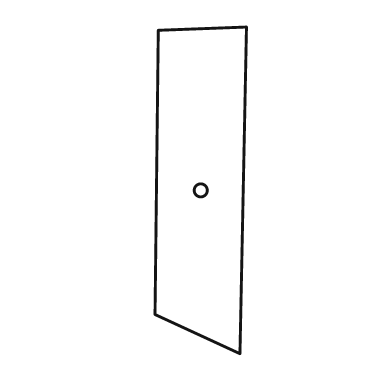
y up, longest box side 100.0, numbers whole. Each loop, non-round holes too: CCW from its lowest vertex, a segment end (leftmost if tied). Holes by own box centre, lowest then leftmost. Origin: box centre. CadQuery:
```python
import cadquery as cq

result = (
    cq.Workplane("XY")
    .moveTo(12.0, -50.0)
    .lineTo(14.0, 50.0)
    .lineTo(-13.0, 49.0)
    .lineTo(-14.0, -38.0)
    .close()
    .moveTo(0.0, 0.0)
    .circle(2.0)
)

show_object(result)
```